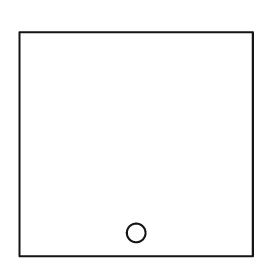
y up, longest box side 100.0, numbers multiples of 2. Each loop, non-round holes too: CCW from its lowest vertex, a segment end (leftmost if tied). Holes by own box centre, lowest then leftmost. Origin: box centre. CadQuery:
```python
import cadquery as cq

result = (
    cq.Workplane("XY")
    .moveTo(-50.0, -48.0)
    .lineTo(50.0, -48.0)
    .lineTo(50.0, 48.0)
    .lineTo(-50.0, 48.0)
    .close()
    .moveTo(0.0, -38.0)
    .circle(4.0)
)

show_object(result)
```